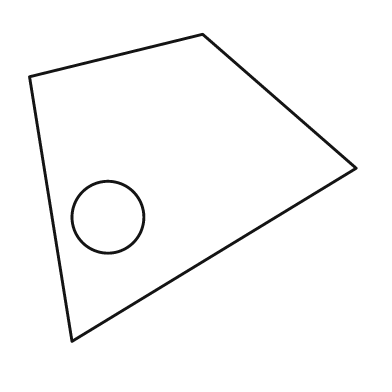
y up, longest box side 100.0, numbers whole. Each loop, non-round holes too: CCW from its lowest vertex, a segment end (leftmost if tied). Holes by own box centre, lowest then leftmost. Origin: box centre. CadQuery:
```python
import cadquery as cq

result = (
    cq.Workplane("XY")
    .moveTo(-37.0, -47.0)
    .lineTo(50.0, 6.0)
    .lineTo(3.0, 47.0)
    .lineTo(-50.0, 34.0)
    .close()
    .moveTo(-26.0, -9.0)
    .circle(11.0)
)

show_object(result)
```